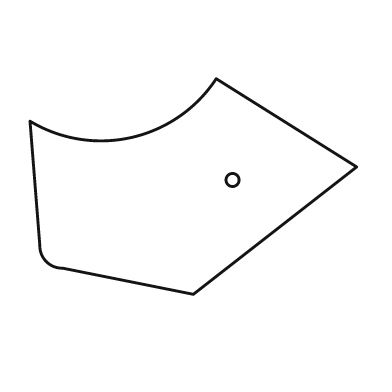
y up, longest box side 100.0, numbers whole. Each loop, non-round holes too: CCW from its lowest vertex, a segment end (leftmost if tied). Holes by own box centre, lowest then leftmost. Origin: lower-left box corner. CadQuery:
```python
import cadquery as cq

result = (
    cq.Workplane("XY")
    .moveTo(50.0, 0.0)
    .lineTo(100.0, 39.0)
    .lineTo(57.0, 66.0)
    .threePointArc((31.0, 48.0), (0.0, 53.0))
    .lineTo(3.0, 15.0)
    .threePointArc((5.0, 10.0), (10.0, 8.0))
    .close()
    .moveTo(62.0, 35.0)
    .circle(2.0)
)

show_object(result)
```